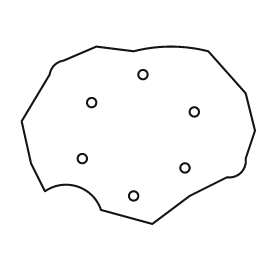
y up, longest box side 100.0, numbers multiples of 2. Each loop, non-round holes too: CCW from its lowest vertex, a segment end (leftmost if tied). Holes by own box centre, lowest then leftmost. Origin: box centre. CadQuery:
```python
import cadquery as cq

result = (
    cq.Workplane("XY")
    .moveTo(6.0, -38.0)
    .lineTo(22.0, -26.0)
    .lineTo(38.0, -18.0)
    .threePointArc((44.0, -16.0), (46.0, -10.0))
    .lineTo(50.0, 2.0)
    .lineTo(46.0, 18.0)
    .lineTo(30.0, 36.0)
    .threePointArc((14.0, 38.0), (-2.0, 36.0))
    .lineTo(-18.0, 38.0)
    .lineTo(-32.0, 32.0)
    .threePointArc((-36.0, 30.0), (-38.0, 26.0))
    .lineTo(-50.0, 6.0)
    .lineTo(-46.0, -12.0)
    .lineTo(-40.0, -24.0)
    .threePointArc((-26.0, -22.0), (-16.0, -32.0))
    .close()
    .moveTo(-2.0, -26.0)
    .circle(2.0)
    .moveTo(20.0, -14.0)
    .circle(2.0)
    .moveTo(-24.0, -10.0)
    .circle(2.0)
    .moveTo(24.0, 10.0)
    .circle(2.0)
    .moveTo(-20.0, 14.0)
    .circle(2.0)
    .moveTo(2.0, 26.0)
    .circle(2.0)
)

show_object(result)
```